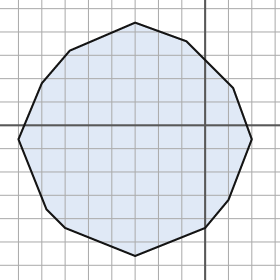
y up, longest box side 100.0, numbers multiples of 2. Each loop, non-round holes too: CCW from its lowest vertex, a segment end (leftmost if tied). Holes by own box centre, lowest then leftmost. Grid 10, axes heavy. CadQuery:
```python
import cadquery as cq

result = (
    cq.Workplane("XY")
    .moveTo(-30.0, -56.0)
    .lineTo(0.0, -44.0)
    .lineTo(10.0, -32.0)
    .lineTo(20.0, -6.0)
    .lineTo(12.0, 16.0)
    .lineTo(-8.0, 36.0)
    .lineTo(-30.0, 44.0)
    .lineTo(-58.0, 32.0)
    .lineTo(-70.0, 18.0)
    .lineTo(-80.0, -6.0)
    .lineTo(-68.0, -36.0)
    .lineTo(-60.0, -44.0)
    .close()
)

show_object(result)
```